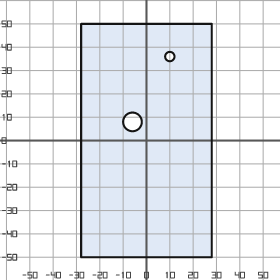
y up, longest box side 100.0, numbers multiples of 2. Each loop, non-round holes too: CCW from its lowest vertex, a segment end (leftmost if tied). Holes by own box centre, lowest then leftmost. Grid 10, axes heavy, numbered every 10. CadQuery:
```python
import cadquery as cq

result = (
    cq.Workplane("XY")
    .moveTo(-28.0, -50.0)
    .lineTo(28.0, -50.0)
    .lineTo(28.0, 50.0)
    .lineTo(-28.0, 50.0)
    .close()
    .moveTo(-6.0, 8.0)
    .circle(4.0)
    .moveTo(10.0, 36.0)
    .circle(2.0)
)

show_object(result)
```